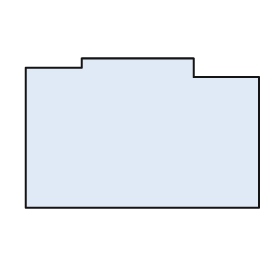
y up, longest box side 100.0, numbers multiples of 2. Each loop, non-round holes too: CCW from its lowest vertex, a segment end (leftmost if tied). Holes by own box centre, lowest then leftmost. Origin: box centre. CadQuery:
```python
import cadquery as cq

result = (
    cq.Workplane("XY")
    .moveTo(-50.0, -32.0)
    .lineTo(50.0, -32.0)
    .lineTo(50.0, 24.0)
    .lineTo(22.0, 24.0)
    .lineTo(22.0, 32.0)
    .lineTo(-26.0, 32.0)
    .lineTo(-26.0, 28.0)
    .lineTo(-50.0, 28.0)
    .close()
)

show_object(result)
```